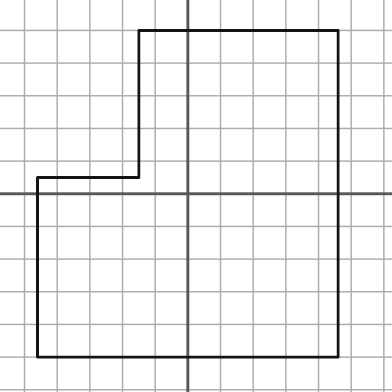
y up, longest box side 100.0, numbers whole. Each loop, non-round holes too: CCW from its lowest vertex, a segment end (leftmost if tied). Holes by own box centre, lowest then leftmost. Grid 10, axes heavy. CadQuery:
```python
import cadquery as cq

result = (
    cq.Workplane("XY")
    .moveTo(-46.0, -50.0)
    .lineTo(46.0, -50.0)
    .lineTo(46.0, 50.0)
    .lineTo(-15.0, 50.0)
    .lineTo(-15.0, 5.0)
    .lineTo(-46.0, 5.0)
    .close()
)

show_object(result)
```